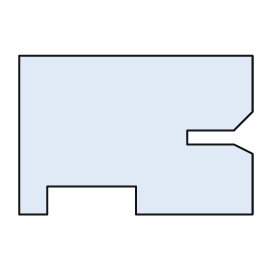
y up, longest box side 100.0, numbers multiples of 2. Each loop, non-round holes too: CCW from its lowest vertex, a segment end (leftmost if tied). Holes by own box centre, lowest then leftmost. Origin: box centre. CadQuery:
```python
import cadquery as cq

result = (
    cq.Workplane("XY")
    .moveTo(-50.0, -34.0)
    .lineTo(-38.0, -34.0)
    .lineTo(-38.0, -22.0)
    .lineTo(0.0, -22.0)
    .lineTo(0.0, -34.0)
    .lineTo(50.0, -34.0)
    .lineTo(50.0, -8.0)
    .lineTo(42.0, -4.0)
    .lineTo(22.0, -4.0)
    .lineTo(22.0, 2.0)
    .lineTo(42.0, 2.0)
    .lineTo(50.0, 10.0)
    .lineTo(50.0, 34.0)
    .lineTo(-50.0, 34.0)
    .close()
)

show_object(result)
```